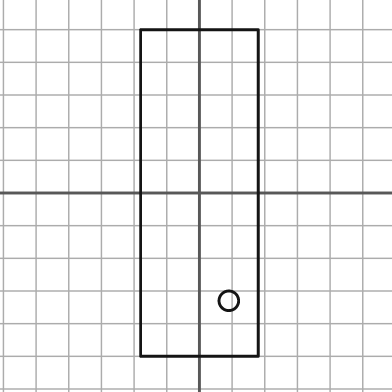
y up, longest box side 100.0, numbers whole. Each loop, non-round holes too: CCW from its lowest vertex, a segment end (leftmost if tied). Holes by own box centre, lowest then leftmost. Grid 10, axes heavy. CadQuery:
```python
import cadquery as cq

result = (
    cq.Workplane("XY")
    .moveTo(-18.0, -50.0)
    .lineTo(18.0, -50.0)
    .lineTo(18.0, 50.0)
    .lineTo(-18.0, 50.0)
    .close()
    .moveTo(9.0, -33.0)
    .circle(3.0)
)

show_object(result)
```